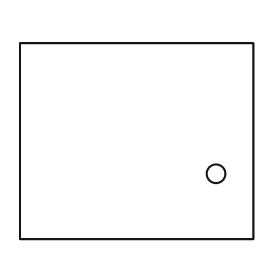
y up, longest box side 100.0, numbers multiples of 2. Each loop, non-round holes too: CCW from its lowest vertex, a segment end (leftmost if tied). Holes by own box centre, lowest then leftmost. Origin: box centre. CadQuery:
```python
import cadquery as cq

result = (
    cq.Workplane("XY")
    .moveTo(-50.0, -42.0)
    .lineTo(50.0, -42.0)
    .lineTo(50.0, 42.0)
    .lineTo(-50.0, 42.0)
    .close()
    .moveTo(34.0, -14.0)
    .circle(4.0)
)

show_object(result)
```